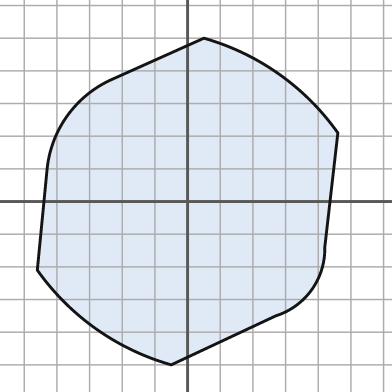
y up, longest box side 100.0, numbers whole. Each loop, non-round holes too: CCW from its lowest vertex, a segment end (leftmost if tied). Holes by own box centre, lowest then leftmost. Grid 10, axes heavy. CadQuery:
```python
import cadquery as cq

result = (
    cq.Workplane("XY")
    .moveTo(-5.0, -50.0)
    .lineTo(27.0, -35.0)
    .threePointArc((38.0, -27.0), (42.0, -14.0))
    .lineTo(46.0, 21.0)
    .threePointArc((28.0, 39.0), (5.0, 50.0))
    .lineTo(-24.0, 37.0)
    .threePointArc((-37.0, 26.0), (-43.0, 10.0))
    .lineTo(-46.0, -21.0)
    .threePointArc((-28.0, -39.0), (-5.0, -50.0))
    .close()
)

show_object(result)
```